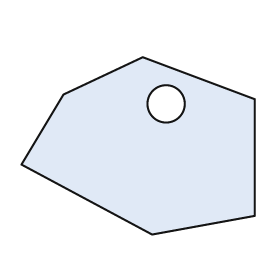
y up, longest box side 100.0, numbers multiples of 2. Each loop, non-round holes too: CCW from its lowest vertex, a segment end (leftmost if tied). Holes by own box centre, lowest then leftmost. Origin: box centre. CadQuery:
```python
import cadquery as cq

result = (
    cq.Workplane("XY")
    .moveTo(6.0, -38.0)
    .lineTo(50.0, -30.0)
    .lineTo(50.0, 20.0)
    .lineTo(2.0, 38.0)
    .lineTo(-32.0, 22.0)
    .lineTo(-50.0, -8.0)
    .close()
    .moveTo(12.0, 18.0)
    .circle(8.0)
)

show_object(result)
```